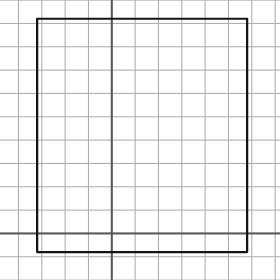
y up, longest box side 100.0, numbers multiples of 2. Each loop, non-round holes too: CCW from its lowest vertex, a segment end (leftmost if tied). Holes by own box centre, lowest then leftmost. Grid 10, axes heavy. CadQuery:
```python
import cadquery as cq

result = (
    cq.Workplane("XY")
    .moveTo(-32.0, -8.0)
    .lineTo(58.0, -8.0)
    .lineTo(58.0, 92.0)
    .lineTo(-32.0, 92.0)
    .close()
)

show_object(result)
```